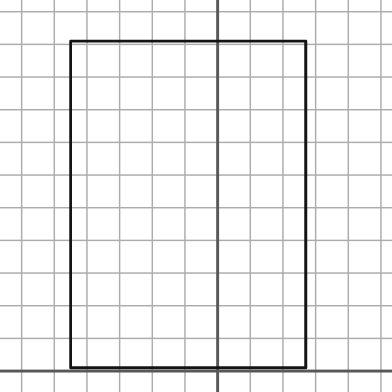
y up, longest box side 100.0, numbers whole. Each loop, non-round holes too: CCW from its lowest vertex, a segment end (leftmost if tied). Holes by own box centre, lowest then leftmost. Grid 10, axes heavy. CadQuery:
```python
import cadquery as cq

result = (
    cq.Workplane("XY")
    .moveTo(-45.0, 1.0)
    .lineTo(27.0, 1.0)
    .lineTo(27.0, 101.0)
    .lineTo(-45.0, 101.0)
    .close()
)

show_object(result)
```